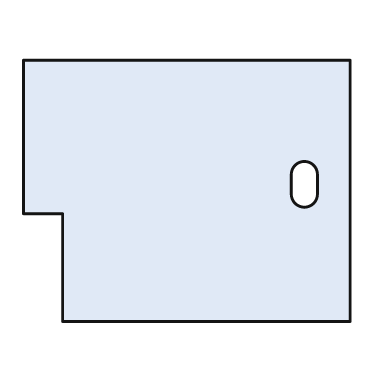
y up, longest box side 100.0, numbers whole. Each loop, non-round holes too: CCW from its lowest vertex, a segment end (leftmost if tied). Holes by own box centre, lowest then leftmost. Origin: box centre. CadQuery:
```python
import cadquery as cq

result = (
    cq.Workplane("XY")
    .moveTo(-38.0, -40.0)
    .lineTo(50.0, -40.0)
    .lineTo(50.0, 40.0)
    .lineTo(-50.0, 40.0)
    .lineTo(-50.0, -7.0)
    .lineTo(-38.0, -7.0)
    .close()
    .moveTo(32.0, -1.0)
    .threePointArc((36.0, -5.0), (40.0, -1.0))
    .lineTo(40.0, 5.0)
    .threePointArc((36.0, 9.0), (32.0, 5.0))
    .close()
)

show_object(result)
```